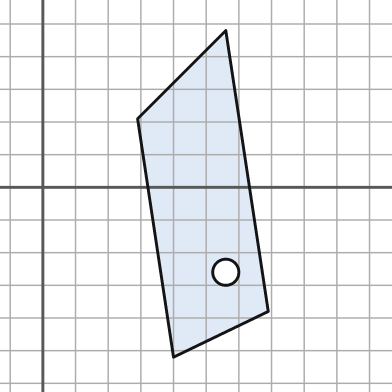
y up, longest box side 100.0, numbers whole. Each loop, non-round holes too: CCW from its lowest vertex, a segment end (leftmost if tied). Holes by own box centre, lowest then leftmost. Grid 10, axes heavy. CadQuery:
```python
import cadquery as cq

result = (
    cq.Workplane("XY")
    .moveTo(40.0, -52.0)
    .lineTo(69.0, -38.0)
    .lineTo(56.0, 48.0)
    .lineTo(29.0, 21.0)
    .close()
    .moveTo(56.0, -26.0)
    .circle(4.0)
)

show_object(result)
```